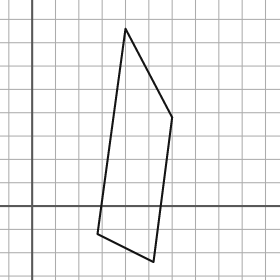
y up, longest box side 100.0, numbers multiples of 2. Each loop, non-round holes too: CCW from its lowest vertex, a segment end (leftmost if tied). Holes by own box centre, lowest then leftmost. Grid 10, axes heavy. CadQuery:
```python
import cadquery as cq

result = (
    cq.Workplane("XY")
    .moveTo(52.0, -24.0)
    .lineTo(60.0, 38.0)
    .lineTo(40.0, 76.0)
    .lineTo(28.0, -12.0)
    .close()
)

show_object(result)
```